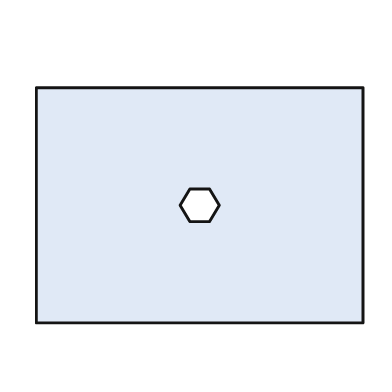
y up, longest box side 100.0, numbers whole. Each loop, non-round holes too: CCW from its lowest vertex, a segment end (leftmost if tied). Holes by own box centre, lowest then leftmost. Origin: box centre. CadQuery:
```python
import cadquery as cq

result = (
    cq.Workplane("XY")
    .moveTo(-50.0, -36.0)
    .lineTo(50.0, -36.0)
    .lineTo(50.0, 36.0)
    .lineTo(-50.0, 36.0)
    .close()
    .moveTo(-3.0, -5.0)
    .lineTo(3.0, -5.0)
    .lineTo(6.0, 0.0)
    .lineTo(3.0, 5.0)
    .lineTo(-3.0, 5.0)
    .lineTo(-6.0, 0.0)
    .close()
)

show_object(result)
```